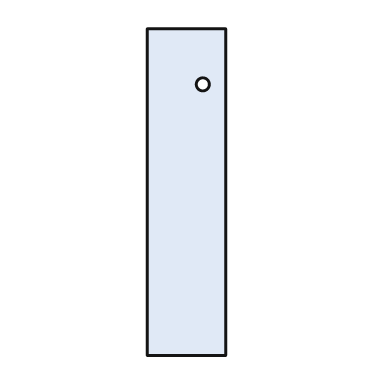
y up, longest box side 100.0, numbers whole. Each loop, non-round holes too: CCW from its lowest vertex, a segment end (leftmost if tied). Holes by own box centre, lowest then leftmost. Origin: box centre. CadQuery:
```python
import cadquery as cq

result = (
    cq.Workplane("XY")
    .moveTo(-12.0, -50.0)
    .lineTo(12.0, -50.0)
    .lineTo(12.0, 50.0)
    .lineTo(-12.0, 50.0)
    .close()
    .moveTo(5.0, 33.0)
    .circle(2.0)
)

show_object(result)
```